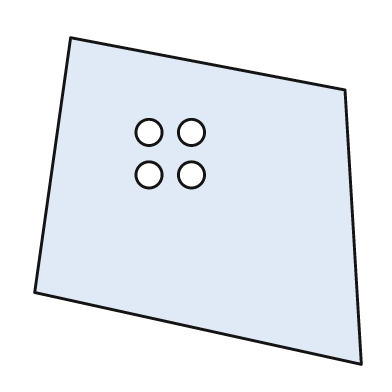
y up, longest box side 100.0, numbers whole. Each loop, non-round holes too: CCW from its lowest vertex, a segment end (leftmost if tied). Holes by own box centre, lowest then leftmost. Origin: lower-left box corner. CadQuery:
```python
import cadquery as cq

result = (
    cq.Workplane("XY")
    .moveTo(100.0, 0.0)
    .lineTo(95.0, 84.0)
    .lineTo(11.0, 100.0)
    .lineTo(0.0, 22.0)
    .close()
    .moveTo(35.0, 58.0)
    .circle(4.0)
    .moveTo(48.0, 58.0)
    .circle(4.0)
    .moveTo(35.0, 71.0)
    .circle(4.0)
    .moveTo(48.0, 71.0)
    .circle(4.0)
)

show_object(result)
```